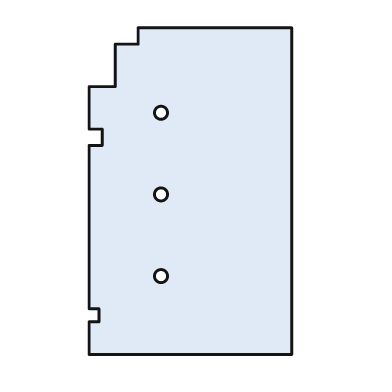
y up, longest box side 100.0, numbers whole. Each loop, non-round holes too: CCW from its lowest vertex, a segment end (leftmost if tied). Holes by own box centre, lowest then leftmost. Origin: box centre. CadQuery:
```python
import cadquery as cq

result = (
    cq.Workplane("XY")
    .moveTo(-31.0, -50.0)
    .lineTo(31.0, -50.0)
    .lineTo(31.0, 50.0)
    .lineTo(-16.0, 50.0)
    .lineTo(-16.0, 45.0)
    .lineTo(-23.0, 45.0)
    .lineTo(-23.0, 32.0)
    .lineTo(-31.0, 32.0)
    .lineTo(-31.0, 19.0)
    .lineTo(-27.0, 19.0)
    .lineTo(-27.0, 14.0)
    .lineTo(-31.0, 14.0)
    .lineTo(-31.0, -36.0)
    .lineTo(-28.0, -36.0)
    .lineTo(-28.0, -40.0)
    .lineTo(-31.0, -40.0)
    .close()
    .moveTo(-9.0, -26.0)
    .circle(2.0)
    .moveTo(-9.0, -1.0)
    .circle(2.0)
    .moveTo(-9.0, 24.0)
    .circle(2.0)
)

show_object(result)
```